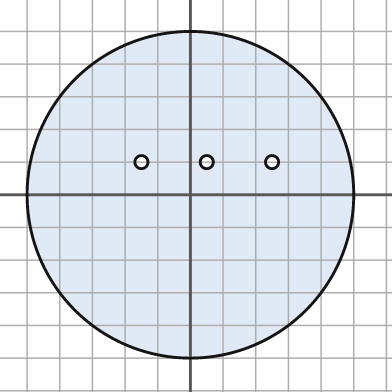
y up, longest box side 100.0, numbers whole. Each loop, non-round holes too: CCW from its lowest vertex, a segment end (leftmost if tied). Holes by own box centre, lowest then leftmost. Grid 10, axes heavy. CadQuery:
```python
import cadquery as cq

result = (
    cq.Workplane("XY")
    .moveTo(0.0, 0.0)
    .circle(50.0)
    .moveTo(-15.0, 10.0)
    .circle(2.0)
    .moveTo(5.0, 10.0)
    .circle(2.0)
    .moveTo(25.0, 10.0)
    .circle(2.0)
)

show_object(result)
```